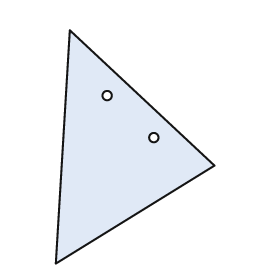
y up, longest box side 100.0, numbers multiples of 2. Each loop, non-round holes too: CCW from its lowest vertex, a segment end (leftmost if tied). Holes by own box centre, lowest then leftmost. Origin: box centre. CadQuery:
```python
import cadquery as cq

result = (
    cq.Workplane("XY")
    .moveTo(-34.0, -50.0)
    .lineTo(34.0, -8.0)
    .lineTo(-28.0, 50.0)
    .close()
    .moveTo(8.0, 4.0)
    .circle(2.0)
    .moveTo(-12.0, 22.0)
    .circle(2.0)
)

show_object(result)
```